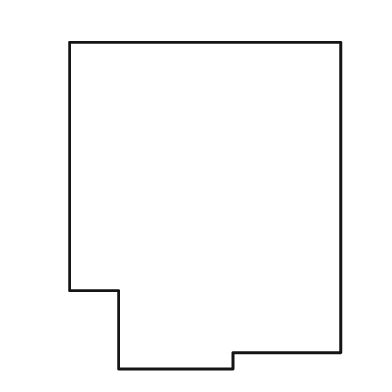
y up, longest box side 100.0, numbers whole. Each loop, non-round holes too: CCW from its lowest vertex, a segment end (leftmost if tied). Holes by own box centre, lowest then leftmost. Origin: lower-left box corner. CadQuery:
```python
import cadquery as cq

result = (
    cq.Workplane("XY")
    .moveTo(15.0, 0.0)
    .lineTo(50.0, 0.0)
    .lineTo(50.0, 5.0)
    .lineTo(83.0, 5.0)
    .lineTo(83.0, 100.0)
    .lineTo(0.0, 100.0)
    .lineTo(0.0, 24.0)
    .lineTo(15.0, 24.0)
    .close()
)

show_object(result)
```